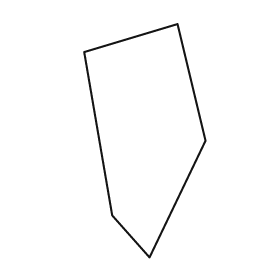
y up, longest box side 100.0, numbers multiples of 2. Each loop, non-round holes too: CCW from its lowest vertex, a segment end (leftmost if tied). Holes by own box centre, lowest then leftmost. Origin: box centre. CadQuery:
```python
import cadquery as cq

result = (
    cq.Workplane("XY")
    .moveTo(2.0, -50.0)
    .lineTo(26.0, 0.0)
    .lineTo(14.0, 50.0)
    .lineTo(-26.0, 38.0)
    .lineTo(-14.0, -32.0)
    .close()
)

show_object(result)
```